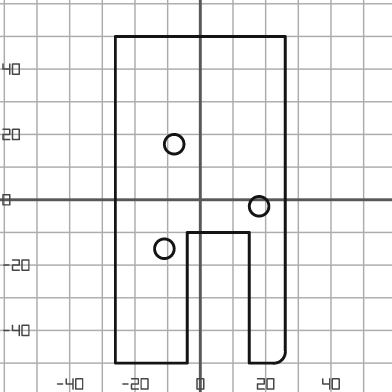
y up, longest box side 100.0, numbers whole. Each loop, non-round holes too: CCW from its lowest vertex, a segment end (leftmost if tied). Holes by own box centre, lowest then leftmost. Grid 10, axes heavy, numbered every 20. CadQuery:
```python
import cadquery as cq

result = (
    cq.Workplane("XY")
    .moveTo(-26.0, -50.0)
    .lineTo(-4.0, -50.0)
    .lineTo(-4.0, -10.0)
    .lineTo(15.0, -10.0)
    .lineTo(15.0, -50.0)
    .lineTo(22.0, -50.0)
    .threePointArc((25.0, -49.0), (26.0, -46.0))
    .lineTo(26.0, 50.0)
    .lineTo(-26.0, 50.0)
    .close()
    .moveTo(-11.0, -15.0)
    .circle(3.0)
    .moveTo(18.0, -2.0)
    .circle(3.0)
    .moveTo(-8.0, 17.0)
    .circle(3.0)
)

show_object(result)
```